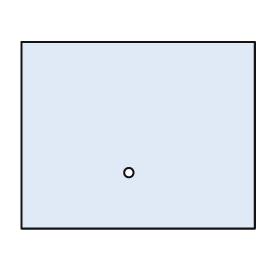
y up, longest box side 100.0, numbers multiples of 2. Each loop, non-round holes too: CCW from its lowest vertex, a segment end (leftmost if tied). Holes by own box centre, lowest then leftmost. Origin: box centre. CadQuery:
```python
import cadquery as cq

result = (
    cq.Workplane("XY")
    .moveTo(-50.0, -40.0)
    .lineTo(50.0, -40.0)
    .lineTo(50.0, 40.0)
    .lineTo(-50.0, 40.0)
    .close()
    .moveTo(-4.0, -16.0)
    .circle(2.0)
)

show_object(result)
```